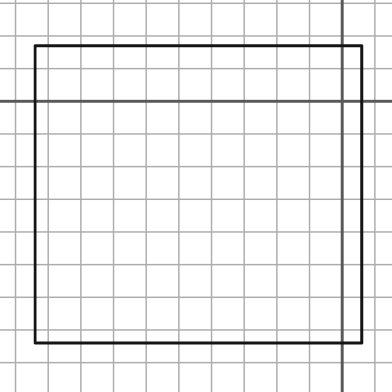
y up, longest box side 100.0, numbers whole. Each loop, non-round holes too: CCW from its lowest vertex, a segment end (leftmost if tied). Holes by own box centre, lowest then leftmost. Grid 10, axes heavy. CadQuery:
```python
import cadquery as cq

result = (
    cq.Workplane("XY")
    .moveTo(-94.0, -74.0)
    .lineTo(6.0, -74.0)
    .lineTo(6.0, 17.0)
    .lineTo(-94.0, 17.0)
    .close()
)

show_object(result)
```